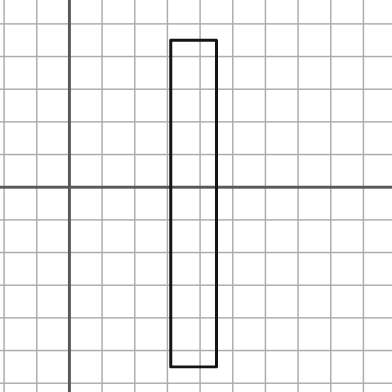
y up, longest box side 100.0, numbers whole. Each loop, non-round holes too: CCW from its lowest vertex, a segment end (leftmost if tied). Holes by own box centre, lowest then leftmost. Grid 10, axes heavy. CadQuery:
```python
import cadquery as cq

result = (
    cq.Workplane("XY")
    .moveTo(31.0, -55.0)
    .lineTo(45.0, -55.0)
    .lineTo(45.0, 45.0)
    .lineTo(31.0, 45.0)
    .close()
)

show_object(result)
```